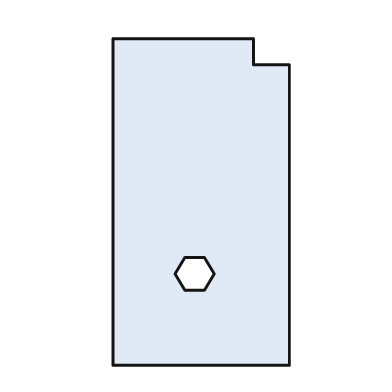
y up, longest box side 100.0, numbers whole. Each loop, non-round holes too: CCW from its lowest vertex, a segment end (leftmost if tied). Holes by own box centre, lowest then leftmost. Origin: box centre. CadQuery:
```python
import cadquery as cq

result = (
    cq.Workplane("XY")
    .moveTo(-27.0, -50.0)
    .lineTo(27.0, -50.0)
    .lineTo(27.0, 42.0)
    .lineTo(16.0, 42.0)
    .lineTo(16.0, 50.0)
    .lineTo(-27.0, 50.0)
    .close()
    .moveTo(-5.0, -27.0)
    .lineTo(1.0, -27.0)
    .lineTo(4.0, -22.0)
    .lineTo(1.0, -17.0)
    .lineTo(-5.0, -17.0)
    .lineTo(-8.0, -22.0)
    .close()
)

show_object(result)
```